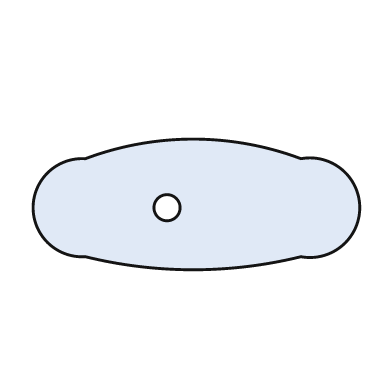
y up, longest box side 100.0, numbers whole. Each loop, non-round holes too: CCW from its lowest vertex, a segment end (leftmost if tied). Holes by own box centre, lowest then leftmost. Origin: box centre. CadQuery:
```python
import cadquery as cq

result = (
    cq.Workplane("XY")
    .moveTo(-34.0, -16.0)
    .threePointArc((-1.0, -20.0), (32.0, -16.0))
    .threePointArc((50.0, -1.0), (32.0, 14.0))
    .threePointArc((-1.0, 20.0), (-34.0, 14.0))
    .threePointArc((-50.0, -1.0), (-34.0, -16.0))
    .close()
    .moveTo(-9.0, -1.0)
    .circle(4.0)
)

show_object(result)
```